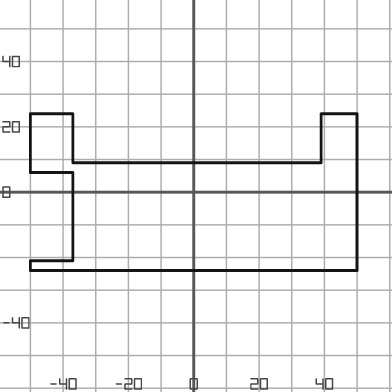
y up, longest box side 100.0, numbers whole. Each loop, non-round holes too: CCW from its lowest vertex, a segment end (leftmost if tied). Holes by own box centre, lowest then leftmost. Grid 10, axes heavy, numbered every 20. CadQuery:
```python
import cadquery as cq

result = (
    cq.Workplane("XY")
    .moveTo(-50.0, -24.0)
    .lineTo(50.0, -24.0)
    .lineTo(50.0, 24.0)
    .lineTo(39.0, 24.0)
    .lineTo(39.0, 9.0)
    .lineTo(-37.0, 9.0)
    .lineTo(-37.0, 24.0)
    .lineTo(-50.0, 24.0)
    .lineTo(-50.0, 6.0)
    .lineTo(-37.0, 6.0)
    .lineTo(-37.0, -21.0)
    .lineTo(-50.0, -21.0)
    .close()
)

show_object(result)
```